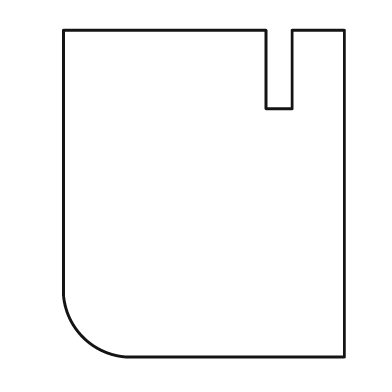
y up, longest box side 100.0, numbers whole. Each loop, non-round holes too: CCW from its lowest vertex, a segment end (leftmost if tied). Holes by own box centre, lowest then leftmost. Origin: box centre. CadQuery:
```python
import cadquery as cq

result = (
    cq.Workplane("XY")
    .moveTo(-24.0, -50.0)
    .lineTo(43.0, -50.0)
    .lineTo(43.0, 50.0)
    .lineTo(27.0, 50.0)
    .lineTo(27.0, 26.0)
    .lineTo(19.0, 26.0)
    .lineTo(19.0, 50.0)
    .lineTo(-43.0, 50.0)
    .lineTo(-43.0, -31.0)
    .threePointArc((-37.0, -44.0), (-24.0, -50.0))
    .close()
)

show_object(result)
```